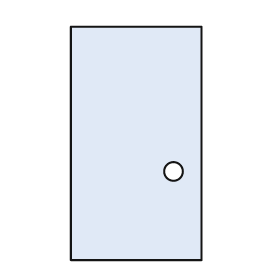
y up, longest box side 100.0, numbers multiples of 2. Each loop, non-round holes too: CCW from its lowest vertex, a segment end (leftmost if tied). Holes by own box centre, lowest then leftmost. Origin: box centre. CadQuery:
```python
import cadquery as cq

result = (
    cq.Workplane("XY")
    .moveTo(-28.0, -50.0)
    .lineTo(28.0, -50.0)
    .lineTo(28.0, 50.0)
    .lineTo(-28.0, 50.0)
    .close()
    .moveTo(16.0, -12.0)
    .circle(4.0)
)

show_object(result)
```